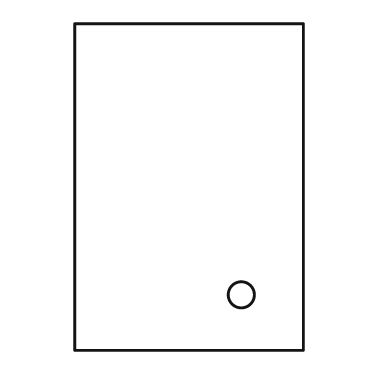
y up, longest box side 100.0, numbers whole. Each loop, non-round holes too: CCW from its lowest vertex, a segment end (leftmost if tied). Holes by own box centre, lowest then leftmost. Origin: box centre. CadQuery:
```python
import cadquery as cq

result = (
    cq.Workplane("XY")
    .moveTo(-35.0, -50.0)
    .lineTo(35.0, -50.0)
    .lineTo(35.0, 50.0)
    .lineTo(-35.0, 50.0)
    .close()
    .moveTo(16.0, -33.0)
    .circle(4.0)
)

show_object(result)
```